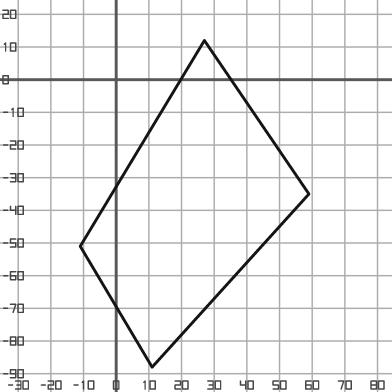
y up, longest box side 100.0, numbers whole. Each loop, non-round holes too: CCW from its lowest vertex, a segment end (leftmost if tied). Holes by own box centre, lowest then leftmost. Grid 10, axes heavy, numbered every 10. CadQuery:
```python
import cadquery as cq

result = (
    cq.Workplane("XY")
    .moveTo(11.0, -88.0)
    .lineTo(59.0, -35.0)
    .lineTo(27.0, 12.0)
    .lineTo(-11.0, -51.0)
    .close()
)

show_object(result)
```